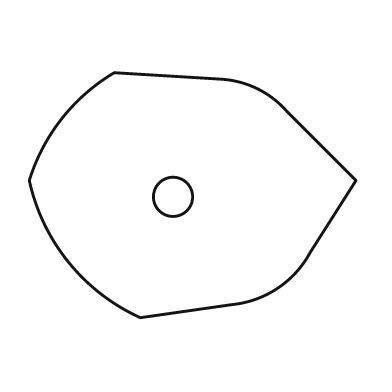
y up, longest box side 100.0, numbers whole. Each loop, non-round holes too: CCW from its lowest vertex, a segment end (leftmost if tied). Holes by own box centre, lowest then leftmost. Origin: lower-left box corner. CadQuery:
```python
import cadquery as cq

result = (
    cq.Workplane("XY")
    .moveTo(34.0, 0.0)
    .lineTo(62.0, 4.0)
    .threePointArc((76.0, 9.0), (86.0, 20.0))
    .lineTo(100.0, 42.0)
    .lineTo(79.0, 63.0)
    .threePointArc((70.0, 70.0), (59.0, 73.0))
    .lineTo(26.0, 75.0)
    .threePointArc((10.0, 61.0), (0.0, 42.0))
    .threePointArc((12.0, 17.0), (34.0, 0.0))
    .close()
    .moveTo(44.0, 37.0)
    .circle(6.0)
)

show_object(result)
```